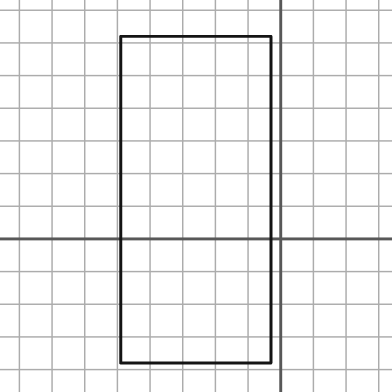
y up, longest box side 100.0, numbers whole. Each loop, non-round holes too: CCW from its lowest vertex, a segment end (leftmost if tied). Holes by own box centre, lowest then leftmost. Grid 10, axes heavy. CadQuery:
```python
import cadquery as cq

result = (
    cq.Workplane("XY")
    .moveTo(-49.0, -38.0)
    .lineTo(-3.0, -38.0)
    .lineTo(-3.0, 62.0)
    .lineTo(-49.0, 62.0)
    .close()
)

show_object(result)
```